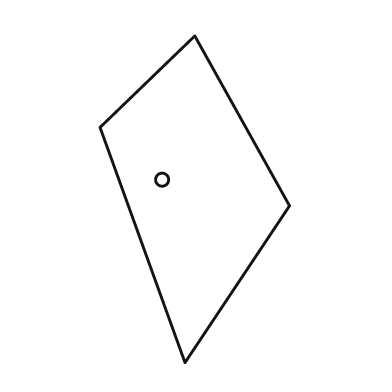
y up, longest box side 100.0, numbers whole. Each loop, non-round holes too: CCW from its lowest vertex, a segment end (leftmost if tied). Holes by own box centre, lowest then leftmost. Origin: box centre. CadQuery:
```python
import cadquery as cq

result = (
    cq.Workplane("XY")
    .moveTo(-3.0, -50.0)
    .lineTo(29.0, -2.0)
    .lineTo(0.0, 50.0)
    .lineTo(-29.0, 22.0)
    .close()
    .moveTo(-10.0, 6.0)
    .circle(2.0)
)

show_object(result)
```